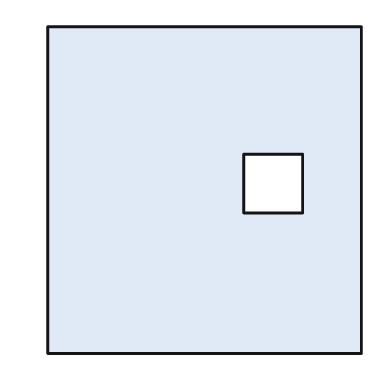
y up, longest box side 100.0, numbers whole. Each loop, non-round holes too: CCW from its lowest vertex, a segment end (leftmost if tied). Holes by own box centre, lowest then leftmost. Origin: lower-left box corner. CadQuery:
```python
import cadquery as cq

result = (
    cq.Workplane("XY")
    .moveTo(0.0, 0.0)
    .lineTo(96.0, 0.0)
    .lineTo(96.0, 100.0)
    .lineTo(0.0, 100.0)
    .close()
    .moveTo(60.0, 43.0)
    .lineTo(78.0, 43.0)
    .lineTo(78.0, 61.0)
    .lineTo(60.0, 61.0)
    .close()
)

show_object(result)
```